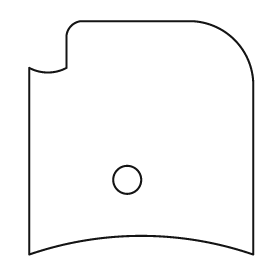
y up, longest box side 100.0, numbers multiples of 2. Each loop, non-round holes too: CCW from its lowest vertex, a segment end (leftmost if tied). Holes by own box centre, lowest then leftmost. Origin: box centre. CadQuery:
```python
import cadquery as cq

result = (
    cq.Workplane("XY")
    .moveTo(-48.0, -50.0)
    .threePointArc((0.0, -42.0), (48.0, -50.0))
    .lineTo(48.0, 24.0)
    .threePointArc((40.0, 42.0), (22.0, 50.0))
    .lineTo(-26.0, 50.0)
    .threePointArc((-30.0, 48.0), (-32.0, 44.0))
    .lineTo(-32.0, 30.0)
    .threePointArc((-40.0, 28.0), (-48.0, 30.0))
    .close()
    .moveTo(-6.0, -18.0)
    .circle(6.0)
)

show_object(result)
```